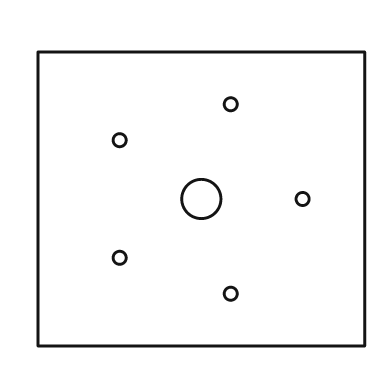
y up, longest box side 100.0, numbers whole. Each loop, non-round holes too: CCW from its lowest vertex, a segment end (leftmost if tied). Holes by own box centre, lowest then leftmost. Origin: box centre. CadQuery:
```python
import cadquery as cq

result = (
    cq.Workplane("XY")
    .moveTo(-50.0, -45.0)
    .lineTo(50.0, -45.0)
    .lineTo(50.0, 45.0)
    .lineTo(-50.0, 45.0)
    .close()
    .moveTo(9.0, -29.0)
    .circle(2.0)
    .moveTo(-25.0, -18.0)
    .circle(2.0)
    .moveTo(0.0, 0.0)
    .circle(6.0)
    .moveTo(31.0, 0.0)
    .circle(2.0)
    .moveTo(-25.0, 18.0)
    .circle(2.0)
    .moveTo(9.0, 29.0)
    .circle(2.0)
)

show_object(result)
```